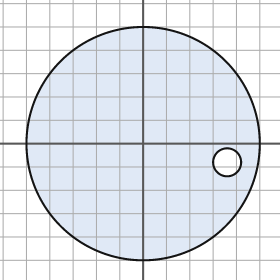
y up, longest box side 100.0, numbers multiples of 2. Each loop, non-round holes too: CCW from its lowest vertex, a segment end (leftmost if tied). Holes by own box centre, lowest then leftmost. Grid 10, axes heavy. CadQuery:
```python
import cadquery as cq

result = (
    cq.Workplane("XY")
    .moveTo(0.0, 0.0)
    .circle(50.0)
    .moveTo(36.0, -8.0)
    .circle(6.0)
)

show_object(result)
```